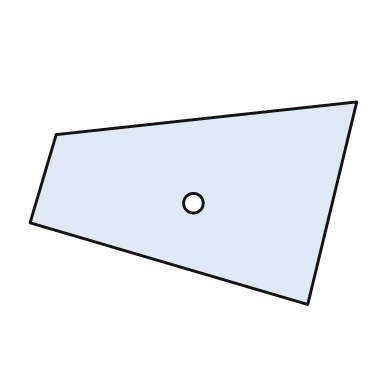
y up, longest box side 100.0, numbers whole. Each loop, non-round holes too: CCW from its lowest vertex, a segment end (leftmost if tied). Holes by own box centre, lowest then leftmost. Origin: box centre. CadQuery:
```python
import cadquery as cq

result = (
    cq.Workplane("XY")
    .moveTo(35.0, -31.0)
    .lineTo(50.0, 31.0)
    .lineTo(-42.0, 21.0)
    .lineTo(-50.0, -6.0)
    .close()
    .moveTo(0.0, 0.0)
    .circle(3.0)
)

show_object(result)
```